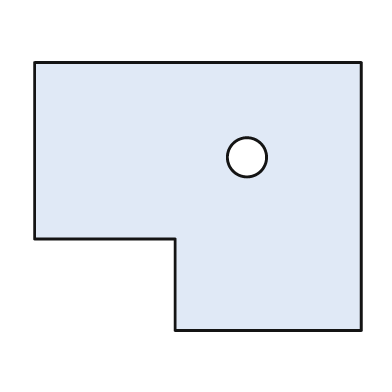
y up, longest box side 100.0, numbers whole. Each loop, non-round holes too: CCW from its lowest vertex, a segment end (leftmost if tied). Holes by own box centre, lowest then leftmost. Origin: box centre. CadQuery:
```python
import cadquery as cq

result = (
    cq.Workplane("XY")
    .moveTo(-7.0, -41.0)
    .lineTo(50.0, -41.0)
    .lineTo(50.0, 41.0)
    .lineTo(-50.0, 41.0)
    .lineTo(-50.0, -13.0)
    .lineTo(-7.0, -13.0)
    .close()
    .moveTo(15.0, 12.0)
    .circle(6.0)
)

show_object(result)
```